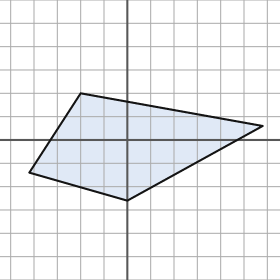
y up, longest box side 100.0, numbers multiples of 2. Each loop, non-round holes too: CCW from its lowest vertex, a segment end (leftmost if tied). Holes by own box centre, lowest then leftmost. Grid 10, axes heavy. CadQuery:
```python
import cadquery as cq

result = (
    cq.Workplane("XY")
    .moveTo(0.0, -26.0)
    .lineTo(58.0, 6.0)
    .lineTo(-20.0, 20.0)
    .lineTo(-42.0, -14.0)
    .close()
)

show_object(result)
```